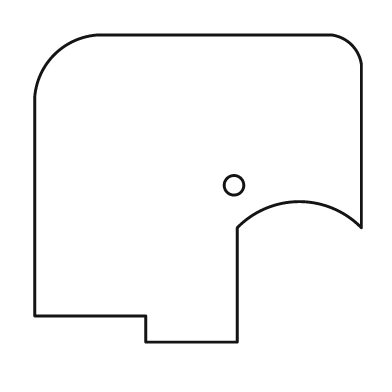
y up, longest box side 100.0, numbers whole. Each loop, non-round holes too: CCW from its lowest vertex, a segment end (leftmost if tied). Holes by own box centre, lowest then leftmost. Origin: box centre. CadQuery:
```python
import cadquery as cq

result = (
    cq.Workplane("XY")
    .moveTo(-16.0, -47.0)
    .lineTo(12.0, -47.0)
    .lineTo(12.0, -12.0)
    .threePointArc((31.0, -4.0), (50.0, -12.0))
    .lineTo(50.0, 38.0)
    .threePointArc((47.0, 44.0), (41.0, 47.0))
    .lineTo(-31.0, 47.0)
    .threePointArc((-44.0, 41.0), (-50.0, 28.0))
    .lineTo(-50.0, -39.0)
    .lineTo(-16.0, -39.0)
    .close()
    .moveTo(11.0, 1.0)
    .circle(3.0)
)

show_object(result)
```